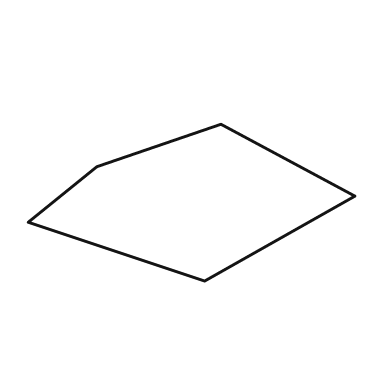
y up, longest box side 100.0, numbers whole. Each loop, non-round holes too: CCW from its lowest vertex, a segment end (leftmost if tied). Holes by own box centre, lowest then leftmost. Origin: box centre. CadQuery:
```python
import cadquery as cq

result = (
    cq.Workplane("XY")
    .moveTo(4.0, -24.0)
    .lineTo(50.0, 2.0)
    .lineTo(9.0, 24.0)
    .lineTo(-29.0, 11.0)
    .lineTo(-50.0, -6.0)
    .close()
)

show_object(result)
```